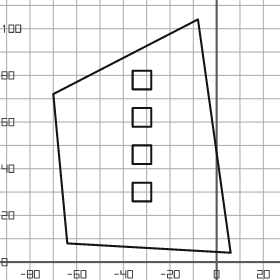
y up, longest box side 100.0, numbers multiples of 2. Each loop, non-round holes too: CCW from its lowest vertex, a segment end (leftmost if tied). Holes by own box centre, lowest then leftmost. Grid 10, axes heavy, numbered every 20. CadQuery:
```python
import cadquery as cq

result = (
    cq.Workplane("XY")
    .moveTo(6.0, 4.0)
    .lineTo(-8.0, 104.0)
    .lineTo(-70.0, 72.0)
    .lineTo(-64.0, 8.0)
    .close()
    .moveTo(-36.0, 26.0)
    .lineTo(-28.0, 26.0)
    .lineTo(-28.0, 34.0)
    .lineTo(-36.0, 34.0)
    .close()
    .moveTo(-36.0, 42.0)
    .lineTo(-28.0, 42.0)
    .lineTo(-28.0, 50.0)
    .lineTo(-36.0, 50.0)
    .close()
    .moveTo(-36.0, 58.0)
    .lineTo(-28.0, 58.0)
    .lineTo(-28.0, 66.0)
    .lineTo(-36.0, 66.0)
    .close()
    .moveTo(-36.0, 74.0)
    .lineTo(-28.0, 74.0)
    .lineTo(-28.0, 82.0)
    .lineTo(-36.0, 82.0)
    .close()
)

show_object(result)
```